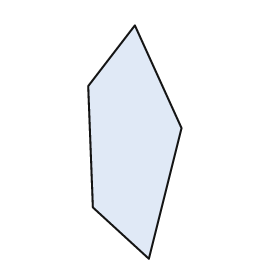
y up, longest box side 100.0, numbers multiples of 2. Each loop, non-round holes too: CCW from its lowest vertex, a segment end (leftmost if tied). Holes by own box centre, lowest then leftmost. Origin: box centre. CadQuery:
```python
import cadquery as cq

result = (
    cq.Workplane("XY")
    .moveTo(6.0, -50.0)
    .lineTo(20.0, 6.0)
    .lineTo(0.0, 50.0)
    .lineTo(-20.0, 24.0)
    .lineTo(-18.0, -28.0)
    .close()
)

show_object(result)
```